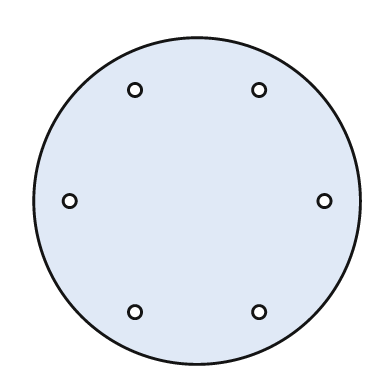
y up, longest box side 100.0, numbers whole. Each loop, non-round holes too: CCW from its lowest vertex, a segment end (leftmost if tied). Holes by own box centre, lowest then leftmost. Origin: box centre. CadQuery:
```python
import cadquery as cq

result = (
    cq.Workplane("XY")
    .moveTo(0.0, 0.0)
    .circle(50.0)
    .moveTo(-19.0, -34.0)
    .circle(2.0)
    .moveTo(19.0, -34.0)
    .circle(2.0)
    .moveTo(-39.0, 0.0)
    .circle(2.0)
    .moveTo(39.0, 0.0)
    .circle(2.0)
    .moveTo(-19.0, 34.0)
    .circle(2.0)
    .moveTo(19.0, 34.0)
    .circle(2.0)
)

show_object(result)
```